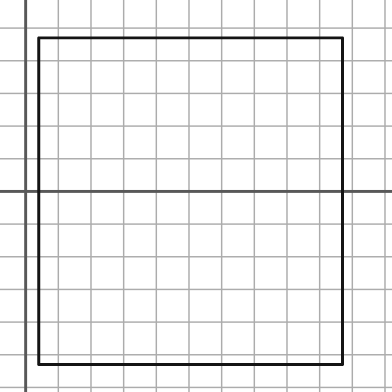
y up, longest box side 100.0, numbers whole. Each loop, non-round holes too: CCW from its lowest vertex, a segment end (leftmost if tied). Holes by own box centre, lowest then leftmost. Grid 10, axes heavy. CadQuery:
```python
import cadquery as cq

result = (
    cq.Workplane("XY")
    .moveTo(4.0, -53.0)
    .lineTo(97.0, -53.0)
    .lineTo(97.0, 47.0)
    .lineTo(4.0, 47.0)
    .close()
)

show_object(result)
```